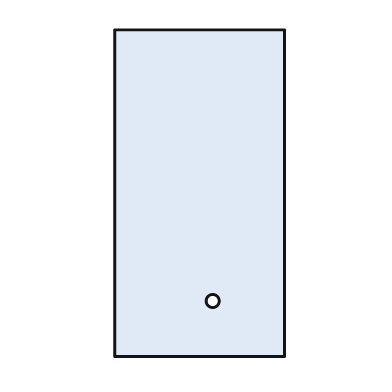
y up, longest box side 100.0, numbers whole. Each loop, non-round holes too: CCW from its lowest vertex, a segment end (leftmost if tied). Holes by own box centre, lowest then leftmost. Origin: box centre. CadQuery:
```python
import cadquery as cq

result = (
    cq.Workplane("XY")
    .moveTo(-26.0, -50.0)
    .lineTo(26.0, -50.0)
    .lineTo(26.0, 50.0)
    .lineTo(-26.0, 50.0)
    .close()
    .moveTo(4.0, -33.0)
    .circle(2.0)
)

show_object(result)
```